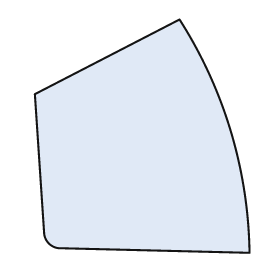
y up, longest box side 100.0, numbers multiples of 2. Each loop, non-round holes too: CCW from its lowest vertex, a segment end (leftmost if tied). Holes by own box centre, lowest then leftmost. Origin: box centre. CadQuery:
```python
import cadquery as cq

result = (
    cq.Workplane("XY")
    .moveTo(46.0, -50.0)
    .threePointArc((38.0, 2.0), (16.0, 50.0))
    .lineTo(-46.0, 18.0)
    .lineTo(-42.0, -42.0)
    .threePointArc((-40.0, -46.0), (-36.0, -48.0))
    .close()
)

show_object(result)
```